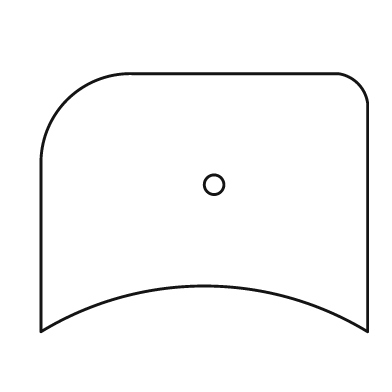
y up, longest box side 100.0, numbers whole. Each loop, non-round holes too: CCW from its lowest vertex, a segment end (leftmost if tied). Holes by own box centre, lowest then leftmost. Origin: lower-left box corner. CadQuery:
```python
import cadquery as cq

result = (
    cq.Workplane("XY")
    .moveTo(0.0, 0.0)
    .threePointArc((50.0, 14.0), (100.0, 0.0))
    .lineTo(100.0, 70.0)
    .threePointArc((97.0, 76.0), (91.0, 79.0))
    .lineTo(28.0, 79.0)
    .threePointArc((8.0, 71.0), (0.0, 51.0))
    .close()
    .moveTo(53.0, 45.0)
    .circle(3.0)
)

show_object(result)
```